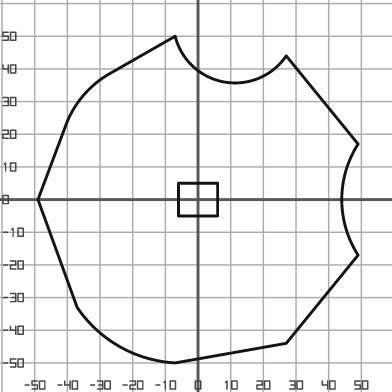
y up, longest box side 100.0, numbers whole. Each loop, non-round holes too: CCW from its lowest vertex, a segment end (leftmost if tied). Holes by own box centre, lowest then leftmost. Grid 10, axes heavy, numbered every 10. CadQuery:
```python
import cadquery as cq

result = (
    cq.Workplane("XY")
    .moveTo(-7.0, -50.0)
    .lineTo(27.0, -44.0)
    .lineTo(49.0, -17.0)
    .threePointArc((44.0, 0.0), (49.0, 17.0))
    .lineTo(27.0, 44.0)
    .threePointArc((8.0, 36.0), (-7.0, 50.0))
    .lineTo(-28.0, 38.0)
    .threePointArc((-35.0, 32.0), (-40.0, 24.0))
    .lineTo(-49.0, 0.0)
    .lineTo(-37.0, -33.0)
    .threePointArc((-24.0, -45.0), (-7.0, -50.0))
    .close()
    .moveTo(-6.0, -5.0)
    .lineTo(6.0, -5.0)
    .lineTo(6.0, 5.0)
    .lineTo(-6.0, 5.0)
    .close()
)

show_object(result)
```